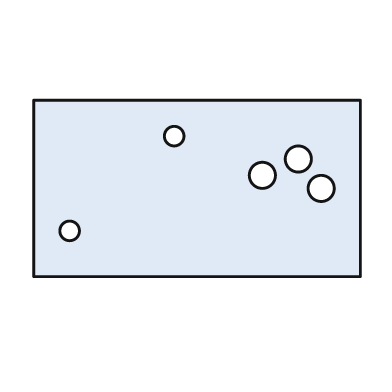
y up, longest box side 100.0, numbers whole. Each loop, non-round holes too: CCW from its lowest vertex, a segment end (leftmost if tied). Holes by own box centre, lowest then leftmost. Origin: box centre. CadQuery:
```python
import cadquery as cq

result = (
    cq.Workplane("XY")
    .moveTo(-50.0, -27.0)
    .lineTo(50.0, -27.0)
    .lineTo(50.0, 27.0)
    .lineTo(-50.0, 27.0)
    .close()
    .moveTo(-39.0, -13.0)
    .circle(3.0)
    .moveTo(38.0, 0.0)
    .circle(4.0)
    .moveTo(20.0, 4.0)
    .circle(4.0)
    .moveTo(31.0, 9.0)
    .circle(4.0)
    .moveTo(-7.0, 16.0)
    .circle(3.0)
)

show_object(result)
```